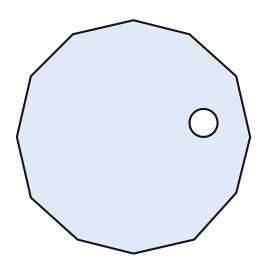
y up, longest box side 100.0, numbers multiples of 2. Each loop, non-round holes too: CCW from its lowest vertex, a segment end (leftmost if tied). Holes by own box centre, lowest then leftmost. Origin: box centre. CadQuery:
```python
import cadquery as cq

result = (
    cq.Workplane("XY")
    .moveTo(0.0, -50.0)
    .lineTo(26.0, -44.0)
    .lineTo(44.0, -24.0)
    .lineTo(50.0, 0.0)
    .lineTo(44.0, 26.0)
    .lineTo(24.0, 44.0)
    .lineTo(0.0, 50.0)
    .lineTo(-26.0, 44.0)
    .lineTo(-44.0, 26.0)
    .lineTo(-50.0, 0.0)
    .lineTo(-44.0, -26.0)
    .lineTo(-24.0, -44.0)
    .close()
    .moveTo(30.0, 6.0)
    .circle(6.0)
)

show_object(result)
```